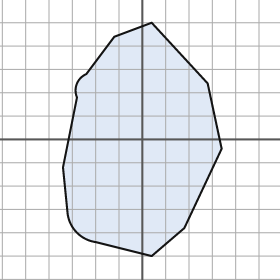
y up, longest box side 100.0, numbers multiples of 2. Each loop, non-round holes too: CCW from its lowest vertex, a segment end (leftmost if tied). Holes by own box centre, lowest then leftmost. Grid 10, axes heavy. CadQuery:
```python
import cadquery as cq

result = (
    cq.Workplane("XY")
    .moveTo(4.0, -50.0)
    .lineTo(18.0, -38.0)
    .lineTo(34.0, -4.0)
    .lineTo(28.0, 24.0)
    .lineTo(4.0, 50.0)
    .lineTo(-12.0, 44.0)
    .lineTo(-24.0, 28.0)
    .threePointArc((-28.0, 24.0), (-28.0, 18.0))
    .lineTo(-34.0, -12.0)
    .lineTo(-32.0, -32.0)
    .threePointArc((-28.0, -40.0), (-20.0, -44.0))
    .close()
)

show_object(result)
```